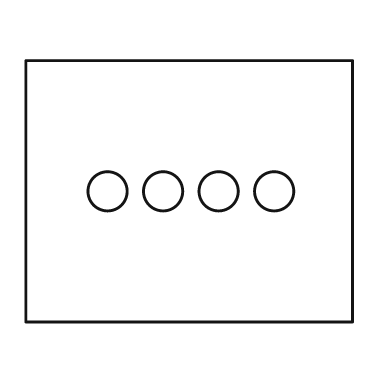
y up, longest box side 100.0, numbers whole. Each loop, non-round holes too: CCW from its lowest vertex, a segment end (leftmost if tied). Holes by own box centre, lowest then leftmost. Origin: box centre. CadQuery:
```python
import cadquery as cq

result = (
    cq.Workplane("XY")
    .moveTo(-50.0, -40.0)
    .lineTo(50.0, -40.0)
    .lineTo(50.0, 40.0)
    .lineTo(-50.0, 40.0)
    .close()
    .moveTo(-25.0, 0.0)
    .circle(6.0)
    .moveTo(-8.0, 0.0)
    .circle(6.0)
    .moveTo(9.0, 0.0)
    .circle(6.0)
    .moveTo(26.0, 0.0)
    .circle(6.0)
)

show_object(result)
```